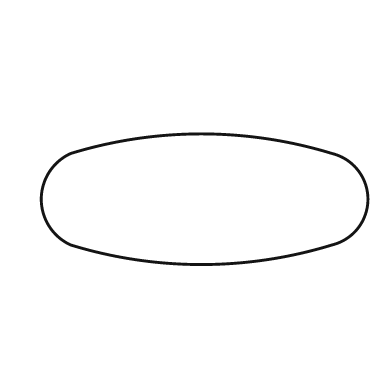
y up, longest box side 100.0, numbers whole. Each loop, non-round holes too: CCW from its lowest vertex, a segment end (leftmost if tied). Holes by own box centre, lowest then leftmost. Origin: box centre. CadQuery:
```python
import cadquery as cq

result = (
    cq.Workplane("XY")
    .moveTo(-41.0, -14.0)
    .threePointArc((-1.0, -20.0), (39.0, -14.0))
    .threePointArc((50.0, 0.0), (39.0, 14.0))
    .threePointArc((-1.0, 20.0), (-41.0, 14.0))
    .threePointArc((-50.0, 0.0), (-41.0, -14.0))
    .close()
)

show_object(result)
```